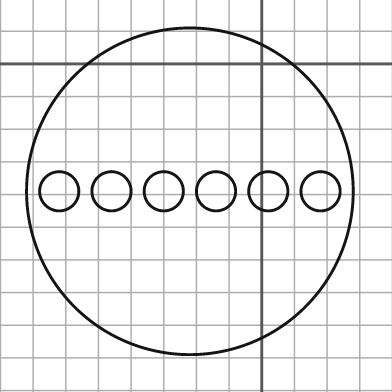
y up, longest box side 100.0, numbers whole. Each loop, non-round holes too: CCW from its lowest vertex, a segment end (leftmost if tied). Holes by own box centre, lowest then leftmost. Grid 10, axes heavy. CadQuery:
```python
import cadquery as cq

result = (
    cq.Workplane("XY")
    .moveTo(-22.0, -39.0)
    .circle(50.0)
    .moveTo(-62.0, -39.0)
    .circle(6.0)
    .moveTo(-46.0, -39.0)
    .circle(6.0)
    .moveTo(-30.0, -39.0)
    .circle(6.0)
    .moveTo(-14.0, -39.0)
    .circle(6.0)
    .moveTo(2.0, -39.0)
    .circle(6.0)
    .moveTo(18.0, -39.0)
    .circle(6.0)
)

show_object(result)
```